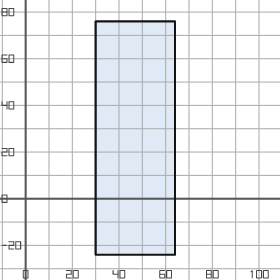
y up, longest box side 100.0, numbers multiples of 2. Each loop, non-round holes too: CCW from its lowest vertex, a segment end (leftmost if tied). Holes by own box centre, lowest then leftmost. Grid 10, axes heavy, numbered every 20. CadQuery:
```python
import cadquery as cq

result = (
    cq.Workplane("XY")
    .moveTo(30.0, -24.0)
    .lineTo(64.0, -24.0)
    .lineTo(64.0, 76.0)
    .lineTo(30.0, 76.0)
    .close()
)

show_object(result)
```